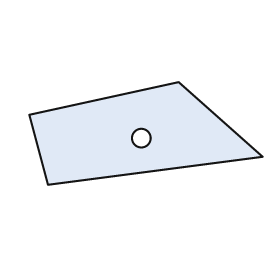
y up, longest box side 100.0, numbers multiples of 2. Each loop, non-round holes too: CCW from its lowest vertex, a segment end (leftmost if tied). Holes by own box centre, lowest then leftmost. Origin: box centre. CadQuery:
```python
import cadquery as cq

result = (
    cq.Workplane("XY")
    .moveTo(-42.0, -22.0)
    .lineTo(50.0, -10.0)
    .lineTo(14.0, 22.0)
    .lineTo(-50.0, 8.0)
    .close()
    .moveTo(-2.0, -2.0)
    .circle(4.0)
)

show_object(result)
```